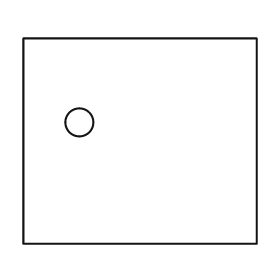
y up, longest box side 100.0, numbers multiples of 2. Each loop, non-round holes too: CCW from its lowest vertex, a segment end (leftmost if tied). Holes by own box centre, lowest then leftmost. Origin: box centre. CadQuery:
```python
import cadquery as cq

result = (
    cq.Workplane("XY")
    .moveTo(-50.0, -44.0)
    .lineTo(50.0, -44.0)
    .lineTo(50.0, 44.0)
    .lineTo(-50.0, 44.0)
    .close()
    .moveTo(-26.0, 8.0)
    .circle(6.0)
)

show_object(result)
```